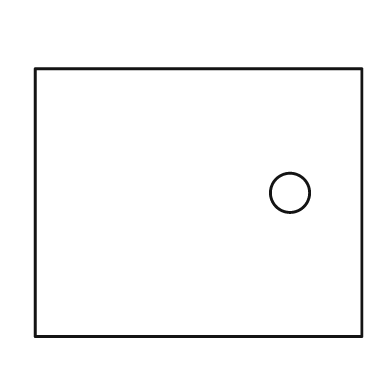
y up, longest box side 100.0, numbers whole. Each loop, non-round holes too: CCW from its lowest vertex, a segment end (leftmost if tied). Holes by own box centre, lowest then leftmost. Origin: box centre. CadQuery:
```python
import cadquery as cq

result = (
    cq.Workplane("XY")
    .moveTo(-50.0, -41.0)
    .lineTo(50.0, -41.0)
    .lineTo(50.0, 41.0)
    .lineTo(-50.0, 41.0)
    .close()
    .moveTo(28.0, 3.0)
    .circle(6.0)
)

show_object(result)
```